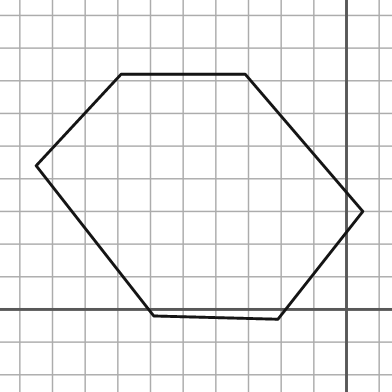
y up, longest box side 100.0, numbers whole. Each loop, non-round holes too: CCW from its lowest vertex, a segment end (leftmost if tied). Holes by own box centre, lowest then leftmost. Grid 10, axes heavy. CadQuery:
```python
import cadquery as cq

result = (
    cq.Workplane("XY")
    .moveTo(-21.0, -3.0)
    .lineTo(5.0, 30.0)
    .lineTo(-31.0, 72.0)
    .lineTo(-69.0, 72.0)
    .lineTo(-95.0, 44.0)
    .lineTo(-59.0, -2.0)
    .close()
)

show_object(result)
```